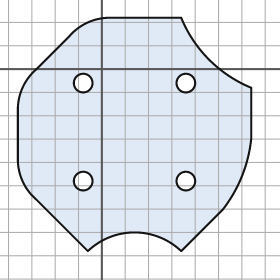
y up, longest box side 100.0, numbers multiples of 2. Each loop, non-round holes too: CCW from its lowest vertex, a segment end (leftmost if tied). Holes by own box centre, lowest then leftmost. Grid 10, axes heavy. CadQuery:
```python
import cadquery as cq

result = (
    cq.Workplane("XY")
    .moveTo(-6.0, -78.0)
    .threePointArc((14.0, -70.0), (34.0, -78.0))
    .lineTo(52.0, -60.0)
    .threePointArc((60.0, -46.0), (64.0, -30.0))
    .lineTo(64.0, -8.0)
    .threePointArc((46.0, 4.0), (34.0, 22.0))
    .lineTo(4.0, 22.0)
    .threePointArc((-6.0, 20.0), (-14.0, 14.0))
    .lineTo(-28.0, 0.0)
    .threePointArc((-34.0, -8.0), (-36.0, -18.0))
    .lineTo(-36.0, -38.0)
    .threePointArc((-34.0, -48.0), (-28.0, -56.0))
    .close()
    .moveTo(-8.0, -48.0)
    .circle(4.0)
    .moveTo(36.0, -48.0)
    .circle(4.0)
    .moveTo(-8.0, -6.0)
    .circle(4.0)
    .moveTo(36.0, -6.0)
    .circle(4.0)
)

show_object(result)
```